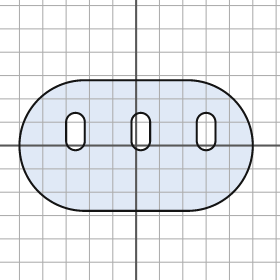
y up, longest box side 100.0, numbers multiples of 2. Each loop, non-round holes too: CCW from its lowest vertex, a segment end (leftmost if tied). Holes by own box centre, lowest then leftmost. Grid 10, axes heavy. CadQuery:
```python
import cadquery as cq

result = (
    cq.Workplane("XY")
    .moveTo(-22.0, -28.0)
    .lineTo(22.0, -28.0)
    .threePointArc((50.0, 0.0), (22.0, 28.0))
    .lineTo(-22.0, 28.0)
    .threePointArc((-50.0, 0.0), (-22.0, -28.0))
    .close()
    .moveTo(-30.0, 2.0)
    .threePointArc((-26.0, -2.0), (-22.0, 2.0))
    .lineTo(-22.0, 10.0)
    .threePointArc((-26.0, 14.0), (-30.0, 10.0))
    .close()
    .moveTo(-2.0, 2.0)
    .threePointArc((2.0, -2.0), (6.0, 2.0))
    .lineTo(6.0, 10.0)
    .threePointArc((2.0, 14.0), (-2.0, 10.0))
    .close()
    .moveTo(26.0, 2.0)
    .threePointArc((30.0, -2.0), (34.0, 2.0))
    .lineTo(34.0, 10.0)
    .threePointArc((30.0, 14.0), (26.0, 10.0))
    .close()
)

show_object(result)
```